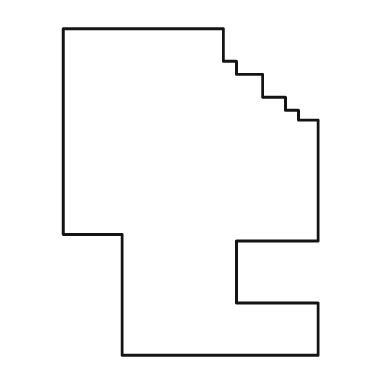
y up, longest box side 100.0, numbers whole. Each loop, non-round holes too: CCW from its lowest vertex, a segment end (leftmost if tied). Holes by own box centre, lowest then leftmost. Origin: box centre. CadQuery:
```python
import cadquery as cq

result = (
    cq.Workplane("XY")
    .moveTo(-21.0, -50.0)
    .lineTo(39.0, -50.0)
    .lineTo(39.0, -34.0)
    .lineTo(14.0, -34.0)
    .lineTo(14.0, -15.0)
    .lineTo(39.0, -15.0)
    .lineTo(39.0, 22.0)
    .lineTo(33.0, 22.0)
    .lineTo(33.0, 25.0)
    .lineTo(29.0, 25.0)
    .lineTo(29.0, 29.0)
    .lineTo(22.0, 29.0)
    .lineTo(22.0, 36.0)
    .lineTo(14.0, 36.0)
    .lineTo(14.0, 40.0)
    .lineTo(10.0, 40.0)
    .lineTo(10.0, 50.0)
    .lineTo(-39.0, 50.0)
    .lineTo(-39.0, -13.0)
    .lineTo(-21.0, -13.0)
    .close()
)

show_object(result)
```